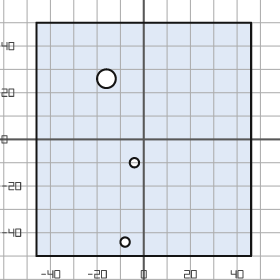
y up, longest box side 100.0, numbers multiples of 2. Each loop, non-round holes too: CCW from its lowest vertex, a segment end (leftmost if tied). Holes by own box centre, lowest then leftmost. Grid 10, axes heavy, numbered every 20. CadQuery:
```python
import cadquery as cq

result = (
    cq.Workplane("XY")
    .moveTo(-46.0, -50.0)
    .lineTo(46.0, -50.0)
    .lineTo(46.0, 50.0)
    .lineTo(-46.0, 50.0)
    .close()
    .moveTo(-8.0, -44.0)
    .circle(2.0)
    .moveTo(-4.0, -10.0)
    .circle(2.0)
    .moveTo(-16.0, 26.0)
    .circle(4.0)
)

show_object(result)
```